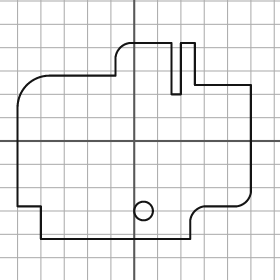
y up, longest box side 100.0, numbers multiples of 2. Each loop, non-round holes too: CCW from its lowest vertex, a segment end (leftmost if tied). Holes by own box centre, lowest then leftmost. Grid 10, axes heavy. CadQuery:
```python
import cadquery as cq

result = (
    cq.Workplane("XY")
    .moveTo(-40.0, -42.0)
    .lineTo(24.0, -42.0)
    .lineTo(24.0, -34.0)
    .threePointArc((26.0, -30.0), (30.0, -28.0))
    .lineTo(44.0, -28.0)
    .threePointArc((48.0, -26.0), (50.0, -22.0))
    .lineTo(50.0, 24.0)
    .lineTo(26.0, 24.0)
    .lineTo(26.0, 42.0)
    .lineTo(20.0, 42.0)
    .lineTo(20.0, 20.0)
    .lineTo(16.0, 20.0)
    .lineTo(16.0, 42.0)
    .lineTo(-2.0, 42.0)
    .threePointArc((-6.0, 40.0), (-8.0, 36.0))
    .lineTo(-8.0, 28.0)
    .lineTo(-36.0, 28.0)
    .threePointArc((-46.0, 24.0), (-50.0, 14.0))
    .lineTo(-50.0, -28.0)
    .lineTo(-40.0, -28.0)
    .close()
    .moveTo(4.0, -30.0)
    .circle(4.0)
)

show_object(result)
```